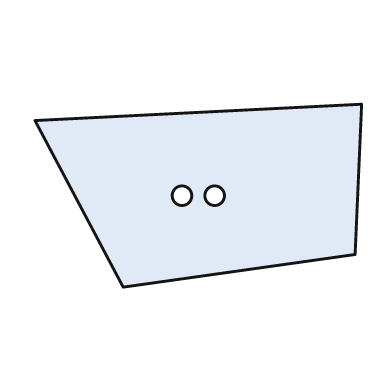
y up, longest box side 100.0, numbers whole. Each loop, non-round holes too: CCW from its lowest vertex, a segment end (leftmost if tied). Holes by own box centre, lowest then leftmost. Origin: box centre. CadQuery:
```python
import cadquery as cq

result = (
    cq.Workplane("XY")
    .moveTo(-23.0, -28.0)
    .lineTo(48.0, -18.0)
    .lineTo(50.0, 28.0)
    .lineTo(-50.0, 23.0)
    .close()
    .moveTo(-5.0, 0.0)
    .circle(3.0)
    .moveTo(5.0, 0.0)
    .circle(3.0)
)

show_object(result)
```